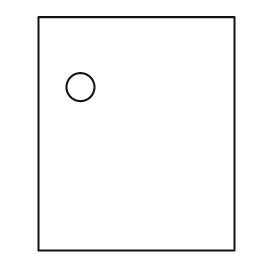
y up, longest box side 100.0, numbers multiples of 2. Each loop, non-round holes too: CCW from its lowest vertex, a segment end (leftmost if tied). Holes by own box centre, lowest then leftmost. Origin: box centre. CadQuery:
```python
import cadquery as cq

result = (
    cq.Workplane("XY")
    .moveTo(-42.0, -50.0)
    .lineTo(42.0, -50.0)
    .lineTo(42.0, 50.0)
    .lineTo(-42.0, 50.0)
    .close()
    .moveTo(-24.0, 20.0)
    .circle(6.0)
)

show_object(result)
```